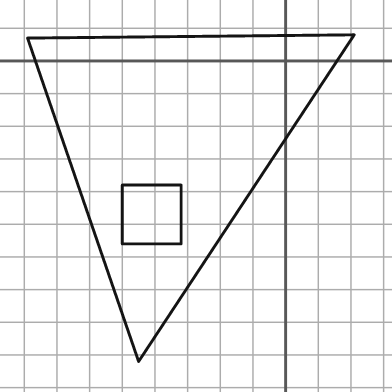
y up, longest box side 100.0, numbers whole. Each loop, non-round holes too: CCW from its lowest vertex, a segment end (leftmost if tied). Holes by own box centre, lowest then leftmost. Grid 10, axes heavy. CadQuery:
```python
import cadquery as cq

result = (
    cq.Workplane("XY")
    .moveTo(-45.0, -92.0)
    .lineTo(21.0, 8.0)
    .lineTo(-79.0, 7.0)
    .close()
    .moveTo(-50.0, -56.0)
    .lineTo(-32.0, -56.0)
    .lineTo(-32.0, -38.0)
    .lineTo(-50.0, -38.0)
    .close()
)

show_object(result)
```